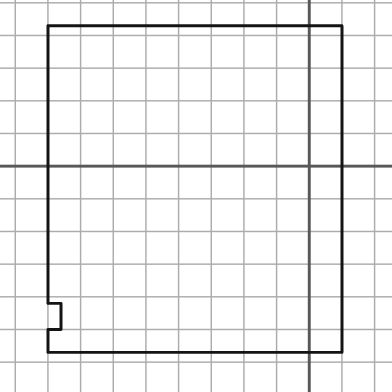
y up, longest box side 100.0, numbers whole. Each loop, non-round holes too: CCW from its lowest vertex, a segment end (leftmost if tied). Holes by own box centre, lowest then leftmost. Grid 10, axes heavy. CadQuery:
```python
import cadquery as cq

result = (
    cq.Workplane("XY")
    .moveTo(-80.0, -57.0)
    .lineTo(10.0, -57.0)
    .lineTo(10.0, 43.0)
    .lineTo(-80.0, 43.0)
    .lineTo(-80.0, -42.0)
    .lineTo(-76.0, -42.0)
    .lineTo(-76.0, -50.0)
    .lineTo(-80.0, -50.0)
    .close()
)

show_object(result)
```